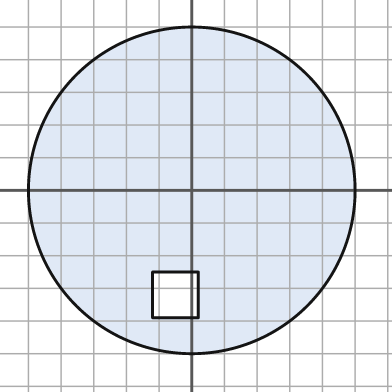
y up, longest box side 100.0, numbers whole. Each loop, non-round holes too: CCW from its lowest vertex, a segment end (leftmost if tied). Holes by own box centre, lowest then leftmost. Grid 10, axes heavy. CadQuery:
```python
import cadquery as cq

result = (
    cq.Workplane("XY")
    .moveTo(0.0, 0.0)
    .circle(50.0)
    .moveTo(-12.0, -39.0)
    .lineTo(2.0, -39.0)
    .lineTo(2.0, -25.0)
    .lineTo(-12.0, -25.0)
    .close()
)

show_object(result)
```